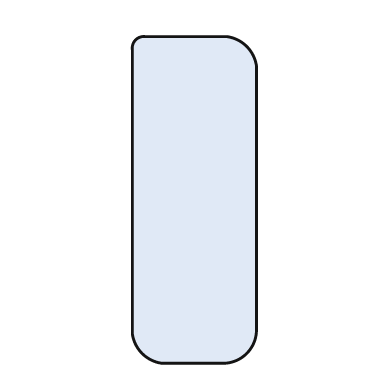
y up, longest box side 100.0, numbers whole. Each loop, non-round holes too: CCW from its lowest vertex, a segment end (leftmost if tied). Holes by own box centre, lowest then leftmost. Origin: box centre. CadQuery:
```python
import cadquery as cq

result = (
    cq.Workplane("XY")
    .moveTo(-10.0, -50.0)
    .lineTo(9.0, -50.0)
    .threePointArc((16.0, -47.0), (19.0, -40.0))
    .lineTo(19.0, 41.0)
    .threePointArc((16.0, 47.0), (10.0, 50.0))
    .lineTo(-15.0, 50.0)
    .threePointArc((-18.0, 49.0), (-19.0, 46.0))
    .lineTo(-19.0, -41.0)
    .threePointArc((-16.0, -47.0), (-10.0, -50.0))
    .close()
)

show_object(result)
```